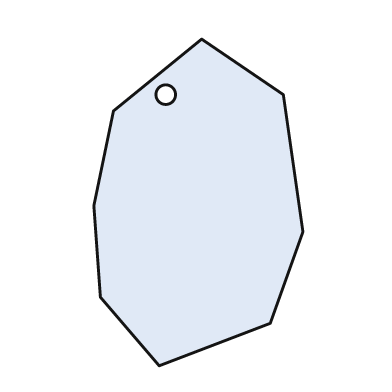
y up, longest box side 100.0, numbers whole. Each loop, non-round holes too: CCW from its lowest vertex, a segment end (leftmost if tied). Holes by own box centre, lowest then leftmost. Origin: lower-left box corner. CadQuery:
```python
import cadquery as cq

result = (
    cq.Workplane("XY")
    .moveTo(20.0, 0.0)
    .lineTo(54.0, 13.0)
    .lineTo(64.0, 41.0)
    .lineTo(58.0, 83.0)
    .lineTo(33.0, 100.0)
    .lineTo(6.0, 78.0)
    .lineTo(0.0, 49.0)
    .lineTo(2.0, 21.0)
    .close()
    .moveTo(22.0, 83.0)
    .circle(3.0)
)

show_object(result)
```